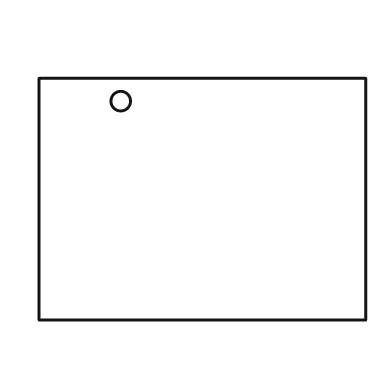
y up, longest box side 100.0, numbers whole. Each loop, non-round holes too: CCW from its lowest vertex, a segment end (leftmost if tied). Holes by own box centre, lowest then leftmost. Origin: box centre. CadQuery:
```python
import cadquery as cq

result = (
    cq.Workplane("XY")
    .moveTo(-50.0, -37.0)
    .lineTo(50.0, -37.0)
    .lineTo(50.0, 37.0)
    .lineTo(-50.0, 37.0)
    .close()
    .moveTo(-25.0, 30.0)
    .circle(3.0)
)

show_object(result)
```